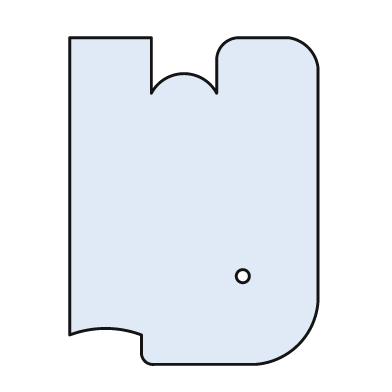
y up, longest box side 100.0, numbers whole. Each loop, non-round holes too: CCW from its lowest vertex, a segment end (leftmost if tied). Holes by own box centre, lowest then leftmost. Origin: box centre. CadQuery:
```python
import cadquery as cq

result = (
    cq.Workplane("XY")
    .moveTo(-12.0, -50.0)
    .lineTo(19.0, -50.0)
    .threePointArc((32.0, -44.0), (38.0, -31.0))
    .lineTo(38.0, 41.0)
    .threePointArc((35.0, 47.0), (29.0, 50.0))
    .lineTo(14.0, 50.0)
    .threePointArc((9.0, 48.0), (7.0, 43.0))
    .lineTo(7.0, 33.0)
    .threePointArc((-3.0, 39.0), (-13.0, 33.0))
    .lineTo(-13.0, 50.0)
    .lineTo(-38.0, 50.0)
    .lineTo(-38.0, -41.0)
    .threePointArc((-27.0, -39.0), (-16.0, -41.0))
    .lineTo(-16.0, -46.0)
    .threePointArc((-15.0, -49.0), (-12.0, -50.0))
    .close()
    .moveTo(15.0, -23.0)
    .circle(2.0)
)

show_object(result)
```